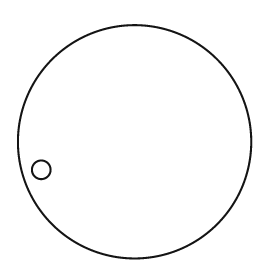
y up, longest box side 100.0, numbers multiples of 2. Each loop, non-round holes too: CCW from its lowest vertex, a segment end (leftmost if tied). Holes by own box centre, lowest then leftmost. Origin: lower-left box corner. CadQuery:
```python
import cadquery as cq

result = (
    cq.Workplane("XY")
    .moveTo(50.0, 50.0)
    .circle(50.0)
    .moveTo(10.0, 38.0)
    .circle(4.0)
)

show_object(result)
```